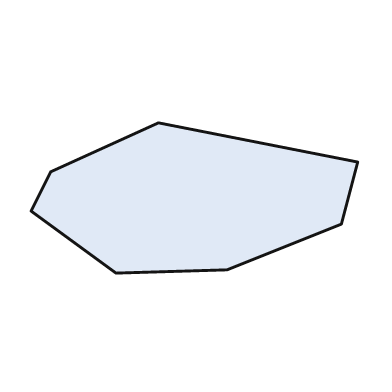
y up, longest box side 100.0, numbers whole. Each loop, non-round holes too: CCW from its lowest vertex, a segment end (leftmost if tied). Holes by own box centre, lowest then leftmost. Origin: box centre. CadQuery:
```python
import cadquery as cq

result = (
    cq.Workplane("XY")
    .moveTo(-24.0, -23.0)
    .lineTo(10.0, -22.0)
    .lineTo(45.0, -8.0)
    .lineTo(50.0, 11.0)
    .lineTo(-11.0, 23.0)
    .lineTo(-44.0, 8.0)
    .lineTo(-50.0, -4.0)
    .close()
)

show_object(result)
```